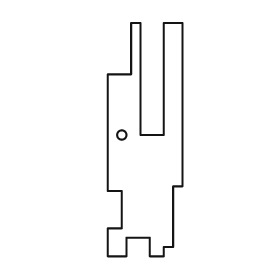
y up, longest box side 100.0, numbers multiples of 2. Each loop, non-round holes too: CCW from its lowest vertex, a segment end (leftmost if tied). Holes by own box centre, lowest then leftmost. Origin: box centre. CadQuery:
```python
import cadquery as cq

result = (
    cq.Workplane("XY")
    .moveTo(-16.0, -50.0)
    .lineTo(-8.0, -50.0)
    .lineTo(-8.0, -42.0)
    .lineTo(2.0, -42.0)
    .lineTo(2.0, -50.0)
    .lineTo(8.0, -50.0)
    .lineTo(8.0, -46.0)
    .lineTo(12.0, -46.0)
    .lineTo(12.0, -20.0)
    .lineTo(16.0, -20.0)
    .lineTo(16.0, 50.0)
    .lineTo(8.0, 50.0)
    .lineTo(8.0, 2.0)
    .lineTo(-2.0, 2.0)
    .lineTo(-2.0, 50.0)
    .lineTo(-6.0, 50.0)
    .lineTo(-6.0, 28.0)
    .lineTo(-16.0, 28.0)
    .lineTo(-16.0, -22.0)
    .lineTo(-10.0, -22.0)
    .lineTo(-10.0, -38.0)
    .lineTo(-16.0, -38.0)
    .close()
    .moveTo(-10.0, 2.0)
    .circle(2.0)
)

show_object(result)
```